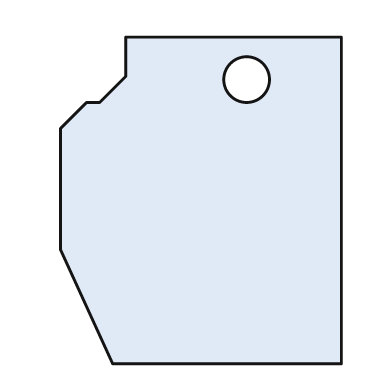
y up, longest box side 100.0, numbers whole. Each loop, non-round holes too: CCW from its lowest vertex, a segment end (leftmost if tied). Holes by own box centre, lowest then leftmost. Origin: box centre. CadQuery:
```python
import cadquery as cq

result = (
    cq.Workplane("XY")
    .moveTo(-27.0, -50.0)
    .lineTo(43.0, -50.0)
    .lineTo(43.0, 50.0)
    .lineTo(-23.0, 50.0)
    .lineTo(-23.0, 38.0)
    .lineTo(-31.0, 30.0)
    .lineTo(-35.0, 30.0)
    .lineTo(-43.0, 22.0)
    .lineTo(-43.0, -15.0)
    .close()
    .moveTo(14.0, 37.0)
    .circle(7.0)
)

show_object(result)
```